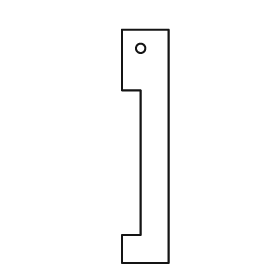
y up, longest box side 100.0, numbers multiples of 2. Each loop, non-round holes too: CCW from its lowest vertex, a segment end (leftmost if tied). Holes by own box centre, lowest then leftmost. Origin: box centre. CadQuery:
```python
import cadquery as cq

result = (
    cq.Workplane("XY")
    .moveTo(-10.0, -50.0)
    .lineTo(10.0, -50.0)
    .lineTo(10.0, 50.0)
    .lineTo(-10.0, 50.0)
    .lineTo(-10.0, 24.0)
    .lineTo(-2.0, 24.0)
    .lineTo(-2.0, -38.0)
    .lineTo(-10.0, -38.0)
    .close()
    .moveTo(-2.0, 42.0)
    .circle(2.0)
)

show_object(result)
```